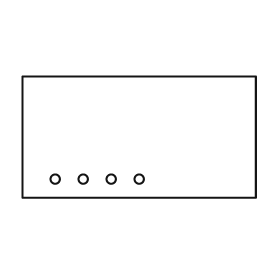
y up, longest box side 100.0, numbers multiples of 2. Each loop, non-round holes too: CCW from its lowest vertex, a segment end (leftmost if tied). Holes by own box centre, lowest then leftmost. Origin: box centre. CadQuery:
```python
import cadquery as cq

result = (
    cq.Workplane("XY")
    .moveTo(-50.0, -26.0)
    .lineTo(50.0, -26.0)
    .lineTo(50.0, 26.0)
    .lineTo(-50.0, 26.0)
    .close()
    .moveTo(-36.0, -18.0)
    .circle(2.0)
    .moveTo(-24.0, -18.0)
    .circle(2.0)
    .moveTo(-12.0, -18.0)
    .circle(2.0)
    .moveTo(0.0, -18.0)
    .circle(2.0)
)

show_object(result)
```